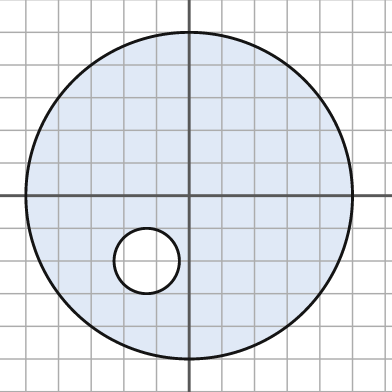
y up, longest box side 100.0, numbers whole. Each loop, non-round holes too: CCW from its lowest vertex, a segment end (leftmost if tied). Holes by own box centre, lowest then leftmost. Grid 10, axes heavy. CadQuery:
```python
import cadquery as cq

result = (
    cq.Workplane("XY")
    .moveTo(0.0, 0.0)
    .circle(50.0)
    .moveTo(-13.0, -20.0)
    .circle(10.0)
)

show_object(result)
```